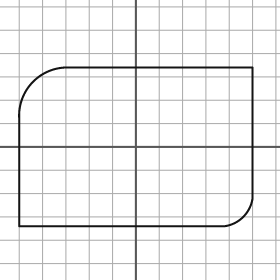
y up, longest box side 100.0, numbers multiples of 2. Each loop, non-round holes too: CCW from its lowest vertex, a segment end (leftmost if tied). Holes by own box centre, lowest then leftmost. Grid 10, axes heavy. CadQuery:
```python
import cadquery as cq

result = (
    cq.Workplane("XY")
    .moveTo(-50.0, -34.0)
    .lineTo(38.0, -34.0)
    .threePointArc((46.0, -30.0), (50.0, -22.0))
    .lineTo(50.0, 34.0)
    .lineTo(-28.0, 34.0)
    .threePointArc((-44.0, 28.0), (-50.0, 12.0))
    .close()
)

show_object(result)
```